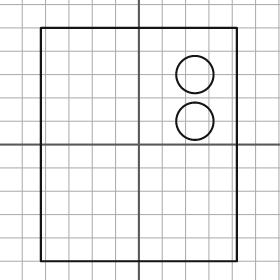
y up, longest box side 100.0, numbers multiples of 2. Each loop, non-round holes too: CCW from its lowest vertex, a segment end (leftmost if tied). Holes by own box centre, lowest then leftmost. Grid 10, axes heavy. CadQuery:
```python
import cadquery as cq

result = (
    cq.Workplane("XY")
    .moveTo(-42.0, -50.0)
    .lineTo(42.0, -50.0)
    .lineTo(42.0, 50.0)
    .lineTo(-42.0, 50.0)
    .close()
    .moveTo(24.0, 10.0)
    .circle(8.0)
    .moveTo(24.0, 30.0)
    .circle(8.0)
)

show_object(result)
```